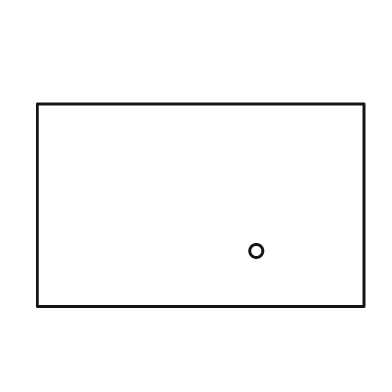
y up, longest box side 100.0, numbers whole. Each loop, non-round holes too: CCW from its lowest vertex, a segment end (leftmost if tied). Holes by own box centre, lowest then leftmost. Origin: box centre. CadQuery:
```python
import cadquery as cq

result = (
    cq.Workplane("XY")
    .moveTo(-50.0, -31.0)
    .lineTo(50.0, -31.0)
    .lineTo(50.0, 31.0)
    .lineTo(-50.0, 31.0)
    .close()
    .moveTo(17.0, -14.0)
    .circle(2.0)
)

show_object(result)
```